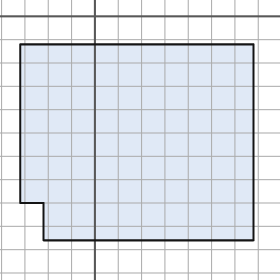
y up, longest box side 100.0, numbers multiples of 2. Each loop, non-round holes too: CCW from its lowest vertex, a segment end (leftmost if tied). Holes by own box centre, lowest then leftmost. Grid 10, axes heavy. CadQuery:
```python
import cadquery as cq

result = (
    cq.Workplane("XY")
    .moveTo(-22.0, -96.0)
    .lineTo(68.0, -96.0)
    .lineTo(68.0, -12.0)
    .lineTo(-32.0, -12.0)
    .lineTo(-32.0, -80.0)
    .lineTo(-22.0, -80.0)
    .close()
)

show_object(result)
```